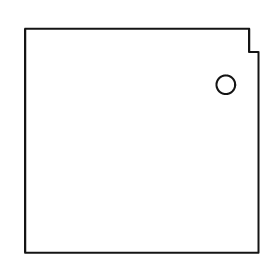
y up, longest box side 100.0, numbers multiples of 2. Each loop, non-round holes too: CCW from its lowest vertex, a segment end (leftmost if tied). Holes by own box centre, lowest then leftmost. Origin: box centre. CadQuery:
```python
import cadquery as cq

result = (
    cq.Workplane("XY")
    .moveTo(-50.0, -48.0)
    .lineTo(50.0, -48.0)
    .lineTo(50.0, 38.0)
    .lineTo(46.0, 38.0)
    .lineTo(46.0, 48.0)
    .lineTo(-50.0, 48.0)
    .close()
    .moveTo(36.0, 24.0)
    .circle(4.0)
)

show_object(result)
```